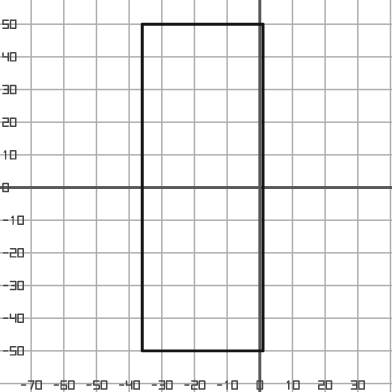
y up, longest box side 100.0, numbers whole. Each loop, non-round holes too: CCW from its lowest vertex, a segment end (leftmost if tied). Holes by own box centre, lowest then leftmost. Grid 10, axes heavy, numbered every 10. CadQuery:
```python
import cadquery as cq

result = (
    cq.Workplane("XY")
    .moveTo(-36.0, -50.0)
    .lineTo(1.0, -50.0)
    .lineTo(1.0, 50.0)
    .lineTo(-36.0, 50.0)
    .close()
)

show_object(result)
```